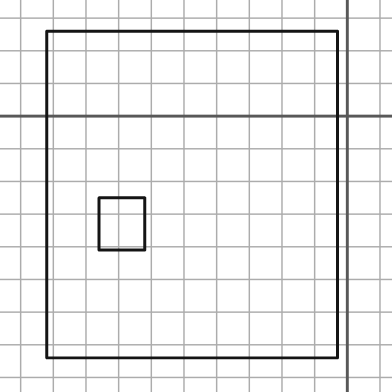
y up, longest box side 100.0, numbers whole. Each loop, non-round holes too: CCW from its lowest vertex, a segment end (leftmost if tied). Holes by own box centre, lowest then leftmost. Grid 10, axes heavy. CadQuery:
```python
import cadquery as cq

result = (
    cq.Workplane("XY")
    .moveTo(-92.0, -74.0)
    .lineTo(-3.0, -74.0)
    .lineTo(-3.0, 26.0)
    .lineTo(-92.0, 26.0)
    .close()
    .moveTo(-76.0, -41.0)
    .lineTo(-62.0, -41.0)
    .lineTo(-62.0, -25.0)
    .lineTo(-76.0, -25.0)
    .close()
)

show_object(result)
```